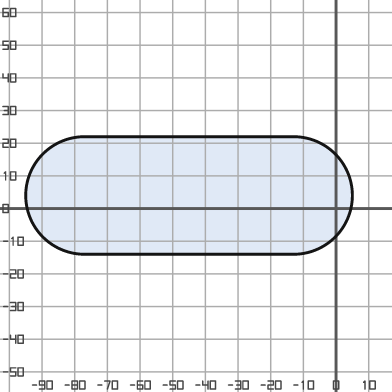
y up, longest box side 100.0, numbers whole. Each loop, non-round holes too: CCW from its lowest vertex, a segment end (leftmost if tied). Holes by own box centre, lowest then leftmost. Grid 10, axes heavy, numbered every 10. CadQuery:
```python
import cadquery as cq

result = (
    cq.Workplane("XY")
    .moveTo(-77.0, -14.0)
    .lineTo(-13.0, -14.0)
    .threePointArc((5.0, 4.0), (-13.0, 22.0))
    .lineTo(-77.0, 22.0)
    .threePointArc((-95.0, 4.0), (-77.0, -14.0))
    .close()
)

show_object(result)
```